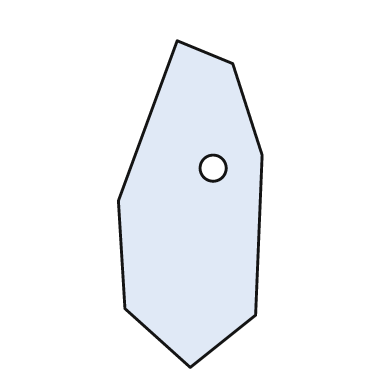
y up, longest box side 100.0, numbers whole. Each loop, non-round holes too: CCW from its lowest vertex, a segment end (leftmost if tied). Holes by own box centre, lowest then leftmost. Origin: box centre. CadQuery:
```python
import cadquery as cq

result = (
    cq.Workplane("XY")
    .moveTo(0.0, -50.0)
    .lineTo(20.0, -34.0)
    .lineTo(22.0, 15.0)
    .lineTo(13.0, 43.0)
    .lineTo(-4.0, 50.0)
    .lineTo(-22.0, 1.0)
    .lineTo(-20.0, -32.0)
    .close()
    .moveTo(7.0, 11.0)
    .circle(4.0)
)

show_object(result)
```